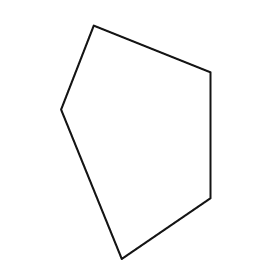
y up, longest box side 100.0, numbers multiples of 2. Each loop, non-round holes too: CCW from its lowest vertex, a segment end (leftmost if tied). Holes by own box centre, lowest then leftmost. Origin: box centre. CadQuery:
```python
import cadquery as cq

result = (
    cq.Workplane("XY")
    .moveTo(-6.0, -50.0)
    .lineTo(32.0, -24.0)
    .lineTo(32.0, 30.0)
    .lineTo(-18.0, 50.0)
    .lineTo(-32.0, 14.0)
    .close()
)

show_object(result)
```